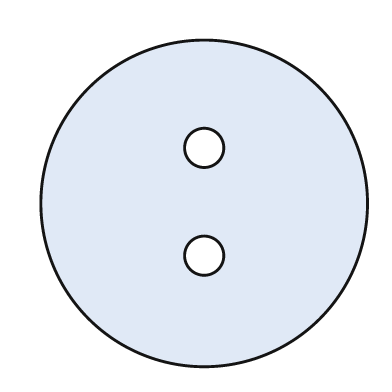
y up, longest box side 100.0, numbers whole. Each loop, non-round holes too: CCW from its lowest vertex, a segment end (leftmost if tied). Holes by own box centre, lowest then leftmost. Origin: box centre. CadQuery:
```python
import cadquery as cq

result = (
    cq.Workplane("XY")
    .moveTo(0.0, 0.0)
    .circle(50.0)
    .moveTo(0.0, -16.0)
    .circle(6.0)
    .moveTo(0.0, 17.0)
    .circle(6.0)
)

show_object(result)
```